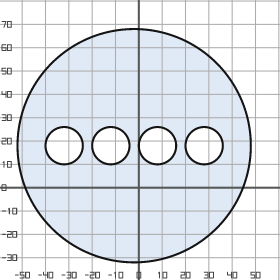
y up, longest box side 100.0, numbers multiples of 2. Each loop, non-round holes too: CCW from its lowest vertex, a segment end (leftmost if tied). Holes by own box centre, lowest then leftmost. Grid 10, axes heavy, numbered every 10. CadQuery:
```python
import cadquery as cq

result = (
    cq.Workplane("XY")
    .moveTo(-2.0, 18.0)
    .circle(50.0)
    .moveTo(-32.0, 18.0)
    .circle(8.0)
    .moveTo(-12.0, 18.0)
    .circle(8.0)
    .moveTo(8.0, 18.0)
    .circle(8.0)
    .moveTo(28.0, 18.0)
    .circle(8.0)
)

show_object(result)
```